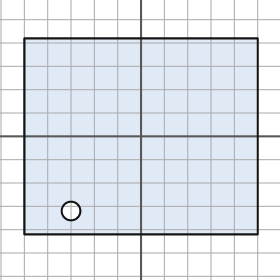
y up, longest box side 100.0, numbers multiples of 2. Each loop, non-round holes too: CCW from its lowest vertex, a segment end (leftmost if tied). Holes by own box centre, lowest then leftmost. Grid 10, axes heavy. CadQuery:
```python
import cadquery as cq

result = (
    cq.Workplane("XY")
    .moveTo(-50.0, -42.0)
    .lineTo(50.0, -42.0)
    .lineTo(50.0, 42.0)
    .lineTo(-50.0, 42.0)
    .close()
    .moveTo(-30.0, -32.0)
    .circle(4.0)
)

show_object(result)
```